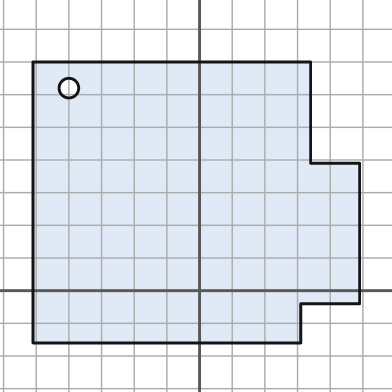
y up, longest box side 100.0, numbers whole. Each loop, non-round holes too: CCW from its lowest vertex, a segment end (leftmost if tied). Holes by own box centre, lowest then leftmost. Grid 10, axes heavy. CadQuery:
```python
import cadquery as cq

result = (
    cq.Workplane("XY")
    .moveTo(-51.0, -16.0)
    .lineTo(31.0, -16.0)
    .lineTo(31.0, -4.0)
    .lineTo(49.0, -4.0)
    .lineTo(49.0, 39.0)
    .lineTo(34.0, 39.0)
    .lineTo(34.0, 70.0)
    .lineTo(-51.0, 70.0)
    .close()
    .moveTo(-40.0, 62.0)
    .circle(3.0)
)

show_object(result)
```